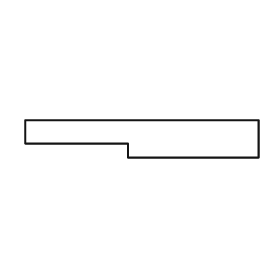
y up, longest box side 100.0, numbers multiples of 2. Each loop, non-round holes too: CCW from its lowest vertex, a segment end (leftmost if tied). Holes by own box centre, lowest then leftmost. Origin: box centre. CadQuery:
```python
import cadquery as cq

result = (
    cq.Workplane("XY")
    .moveTo(-6.0, -8.0)
    .lineTo(50.0, -8.0)
    .lineTo(50.0, 8.0)
    .lineTo(-50.0, 8.0)
    .lineTo(-50.0, -2.0)
    .lineTo(-6.0, -2.0)
    .close()
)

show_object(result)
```